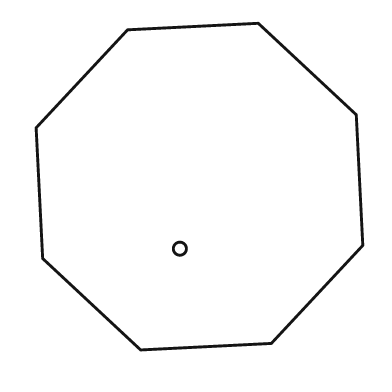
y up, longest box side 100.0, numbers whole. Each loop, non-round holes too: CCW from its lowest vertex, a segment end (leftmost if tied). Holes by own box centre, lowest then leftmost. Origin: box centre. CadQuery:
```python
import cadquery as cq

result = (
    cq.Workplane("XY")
    .moveTo(-18.0, -50.0)
    .lineTo(22.0, -48.0)
    .lineTo(50.0, -18.0)
    .lineTo(48.0, 22.0)
    .lineTo(18.0, 50.0)
    .lineTo(-22.0, 48.0)
    .lineTo(-50.0, 18.0)
    .lineTo(-48.0, -22.0)
    .close()
    .moveTo(-6.0, -19.0)
    .circle(2.0)
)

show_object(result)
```